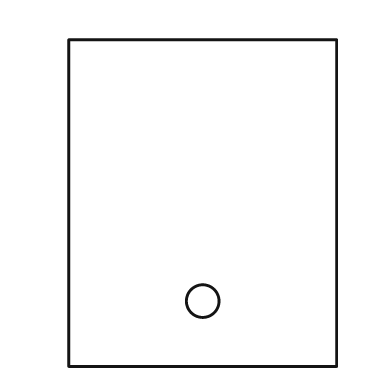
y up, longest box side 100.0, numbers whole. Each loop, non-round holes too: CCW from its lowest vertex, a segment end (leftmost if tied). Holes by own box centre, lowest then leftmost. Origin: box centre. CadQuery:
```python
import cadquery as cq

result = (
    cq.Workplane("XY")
    .moveTo(-41.0, -50.0)
    .lineTo(41.0, -50.0)
    .lineTo(41.0, 50.0)
    .lineTo(-41.0, 50.0)
    .close()
    .moveTo(0.0, -30.0)
    .circle(5.0)
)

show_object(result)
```